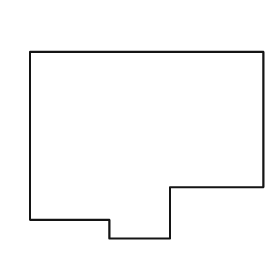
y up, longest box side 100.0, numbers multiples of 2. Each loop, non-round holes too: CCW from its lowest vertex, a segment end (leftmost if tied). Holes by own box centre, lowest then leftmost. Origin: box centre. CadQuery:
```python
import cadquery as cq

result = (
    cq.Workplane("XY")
    .moveTo(-16.0, -40.0)
    .lineTo(10.0, -40.0)
    .lineTo(10.0, -18.0)
    .lineTo(50.0, -18.0)
    .lineTo(50.0, 40.0)
    .lineTo(-50.0, 40.0)
    .lineTo(-50.0, -32.0)
    .lineTo(-16.0, -32.0)
    .close()
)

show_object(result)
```